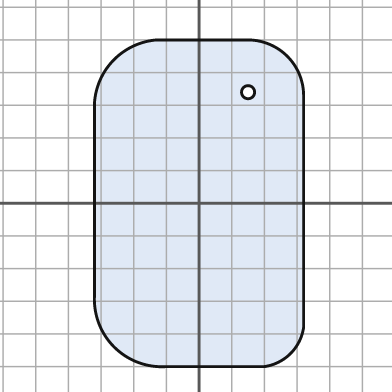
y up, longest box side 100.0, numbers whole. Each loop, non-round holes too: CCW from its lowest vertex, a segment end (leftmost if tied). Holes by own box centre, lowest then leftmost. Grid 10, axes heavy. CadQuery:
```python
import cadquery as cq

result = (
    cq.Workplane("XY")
    .moveTo(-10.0, -50.0)
    .lineTo(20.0, -50.0)
    .threePointArc((28.0, -46.0), (32.0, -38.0))
    .lineTo(32.0, 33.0)
    .threePointArc((27.0, 45.0), (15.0, 50.0))
    .lineTo(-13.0, 50.0)
    .threePointArc((-26.0, 44.0), (-32.0, 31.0))
    .lineTo(-32.0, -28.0)
    .threePointArc((-26.0, -44.0), (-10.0, -50.0))
    .close()
    .moveTo(15.0, 34.0)
    .circle(2.0)
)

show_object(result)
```